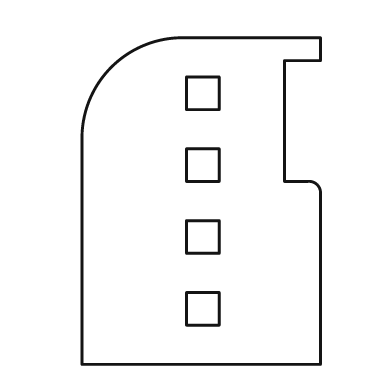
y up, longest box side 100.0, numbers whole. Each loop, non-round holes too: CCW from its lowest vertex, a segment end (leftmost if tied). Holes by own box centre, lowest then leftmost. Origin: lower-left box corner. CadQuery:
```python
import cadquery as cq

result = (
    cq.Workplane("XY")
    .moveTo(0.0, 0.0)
    .lineTo(73.0, 0.0)
    .lineTo(73.0, 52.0)
    .threePointArc((72.0, 55.0), (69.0, 56.0))
    .lineTo(62.0, 56.0)
    .lineTo(62.0, 93.0)
    .lineTo(73.0, 93.0)
    .lineTo(73.0, 100.0)
    .lineTo(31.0, 100.0)
    .threePointArc((9.0, 91.0), (0.0, 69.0))
    .close()
    .moveTo(32.0, 12.0)
    .lineTo(42.0, 12.0)
    .lineTo(42.0, 22.0)
    .lineTo(32.0, 22.0)
    .close()
    .moveTo(32.0, 34.0)
    .lineTo(42.0, 34.0)
    .lineTo(42.0, 44.0)
    .lineTo(32.0, 44.0)
    .close()
    .moveTo(32.0, 56.0)
    .lineTo(42.0, 56.0)
    .lineTo(42.0, 66.0)
    .lineTo(32.0, 66.0)
    .close()
    .moveTo(32.0, 78.0)
    .lineTo(42.0, 78.0)
    .lineTo(42.0, 88.0)
    .lineTo(32.0, 88.0)
    .close()
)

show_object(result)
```